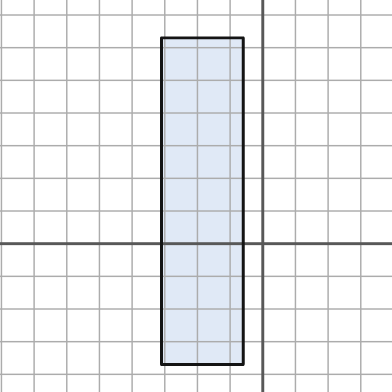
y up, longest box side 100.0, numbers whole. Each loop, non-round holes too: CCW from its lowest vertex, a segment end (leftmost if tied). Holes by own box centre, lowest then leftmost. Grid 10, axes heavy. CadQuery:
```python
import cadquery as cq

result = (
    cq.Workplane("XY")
    .moveTo(-31.0, -37.0)
    .lineTo(-6.0, -37.0)
    .lineTo(-6.0, 63.0)
    .lineTo(-31.0, 63.0)
    .close()
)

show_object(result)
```